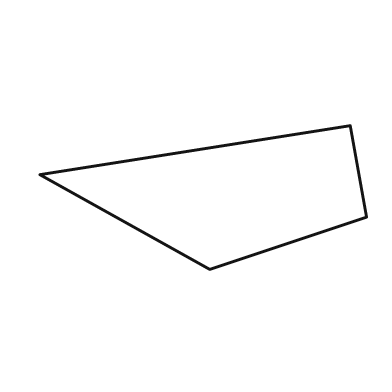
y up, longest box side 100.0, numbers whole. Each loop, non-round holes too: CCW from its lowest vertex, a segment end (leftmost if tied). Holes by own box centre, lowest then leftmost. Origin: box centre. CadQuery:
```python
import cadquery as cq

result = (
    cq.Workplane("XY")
    .moveTo(2.0, -22.0)
    .lineTo(50.0, -6.0)
    .lineTo(45.0, 22.0)
    .lineTo(-50.0, 7.0)
    .close()
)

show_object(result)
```